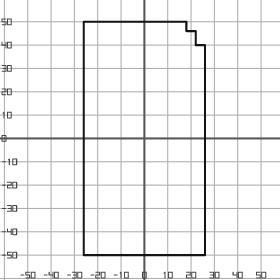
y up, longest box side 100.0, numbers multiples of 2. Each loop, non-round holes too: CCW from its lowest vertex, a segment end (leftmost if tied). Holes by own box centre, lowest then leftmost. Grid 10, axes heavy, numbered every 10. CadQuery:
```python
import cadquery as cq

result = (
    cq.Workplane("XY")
    .moveTo(-26.0, -50.0)
    .lineTo(26.0, -50.0)
    .lineTo(26.0, 40.0)
    .lineTo(22.0, 40.0)
    .lineTo(22.0, 46.0)
    .lineTo(18.0, 46.0)
    .lineTo(18.0, 50.0)
    .lineTo(-26.0, 50.0)
    .close()
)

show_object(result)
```